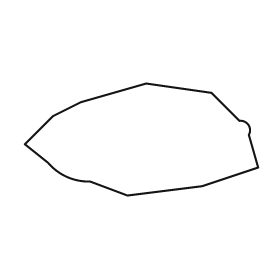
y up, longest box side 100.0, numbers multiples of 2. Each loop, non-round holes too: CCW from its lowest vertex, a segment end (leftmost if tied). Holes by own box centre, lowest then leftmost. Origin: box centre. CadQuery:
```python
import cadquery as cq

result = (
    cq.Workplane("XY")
    .moveTo(-6.0, -24.0)
    .lineTo(26.0, -20.0)
    .lineTo(50.0, -12.0)
    .lineTo(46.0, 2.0)
    .threePointArc((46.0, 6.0), (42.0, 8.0))
    .lineTo(30.0, 20.0)
    .lineTo(2.0, 24.0)
    .lineTo(-26.0, 16.0)
    .lineTo(-38.0, 10.0)
    .lineTo(-50.0, -2.0)
    .lineTo(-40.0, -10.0)
    .threePointArc((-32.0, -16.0), (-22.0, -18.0))
    .close()
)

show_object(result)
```